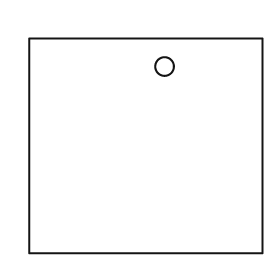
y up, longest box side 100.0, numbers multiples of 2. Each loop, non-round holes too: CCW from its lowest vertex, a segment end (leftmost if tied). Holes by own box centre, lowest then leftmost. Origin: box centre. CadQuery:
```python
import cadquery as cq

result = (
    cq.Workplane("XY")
    .moveTo(-50.0, -46.0)
    .lineTo(50.0, -46.0)
    .lineTo(50.0, 46.0)
    .lineTo(-50.0, 46.0)
    .close()
    .moveTo(8.0, 34.0)
    .circle(4.0)
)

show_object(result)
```